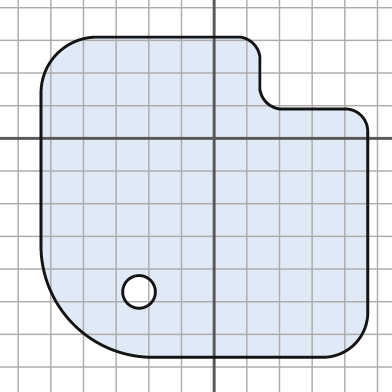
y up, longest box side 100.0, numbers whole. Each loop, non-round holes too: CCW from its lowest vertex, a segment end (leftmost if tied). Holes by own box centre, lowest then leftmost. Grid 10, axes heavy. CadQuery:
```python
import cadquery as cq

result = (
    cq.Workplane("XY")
    .moveTo(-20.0, -67.0)
    .lineTo(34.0, -67.0)
    .threePointArc((43.0, -63.0), (47.0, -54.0))
    .lineTo(47.0, 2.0)
    .threePointArc((45.0, 7.0), (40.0, 9.0))
    .lineTo(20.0, 9.0)
    .threePointArc((16.0, 11.0), (14.0, 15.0))
    .lineTo(14.0, 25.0)
    .threePointArc((12.0, 29.0), (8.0, 31.0))
    .lineTo(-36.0, 31.0)
    .threePointArc((-48.0, 26.0), (-53.0, 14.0))
    .lineTo(-53.0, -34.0)
    .threePointArc((-43.0, -57.0), (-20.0, -67.0))
    .close()
    .moveTo(-23.0, -47.0)
    .circle(5.0)
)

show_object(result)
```